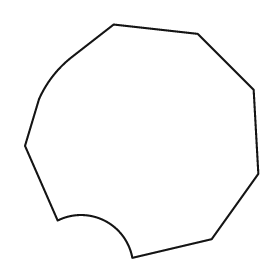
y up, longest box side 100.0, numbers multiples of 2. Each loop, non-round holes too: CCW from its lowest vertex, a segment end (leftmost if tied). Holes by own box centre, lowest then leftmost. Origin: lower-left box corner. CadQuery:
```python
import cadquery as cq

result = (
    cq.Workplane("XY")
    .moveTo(46.0, 0.0)
    .lineTo(80.0, 8.0)
    .lineTo(100.0, 36.0)
    .lineTo(98.0, 72.0)
    .lineTo(74.0, 96.0)
    .lineTo(38.0, 100.0)
    .lineTo(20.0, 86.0)
    .threePointArc((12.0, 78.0), (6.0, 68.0))
    .lineTo(0.0, 48.0)
    .lineTo(14.0, 16.0)
    .threePointArc((34.0, 16.0), (46.0, 0.0))
    .close()
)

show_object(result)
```